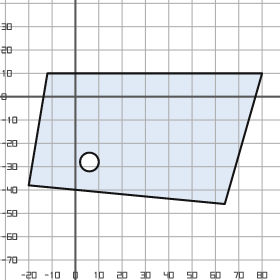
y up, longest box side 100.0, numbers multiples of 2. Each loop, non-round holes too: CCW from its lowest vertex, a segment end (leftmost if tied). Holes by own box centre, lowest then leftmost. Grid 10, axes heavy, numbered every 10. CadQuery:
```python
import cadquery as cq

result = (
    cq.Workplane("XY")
    .moveTo(64.0, -46.0)
    .lineTo(80.0, 10.0)
    .lineTo(-12.0, 10.0)
    .lineTo(-20.0, -38.0)
    .close()
    .moveTo(6.0, -28.0)
    .circle(4.0)
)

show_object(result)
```